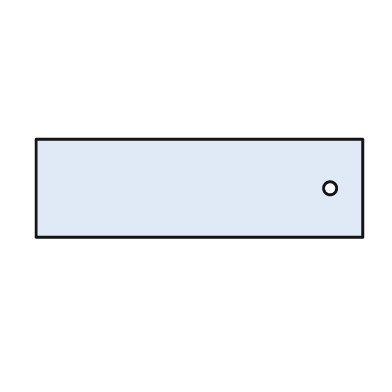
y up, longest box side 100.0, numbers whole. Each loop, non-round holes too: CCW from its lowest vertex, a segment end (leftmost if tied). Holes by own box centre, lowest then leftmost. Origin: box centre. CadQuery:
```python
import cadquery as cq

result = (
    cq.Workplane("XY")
    .moveTo(-50.0, -15.0)
    .lineTo(50.0, -15.0)
    .lineTo(50.0, 15.0)
    .lineTo(-50.0, 15.0)
    .close()
    .moveTo(40.0, 0.0)
    .circle(2.0)
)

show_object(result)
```